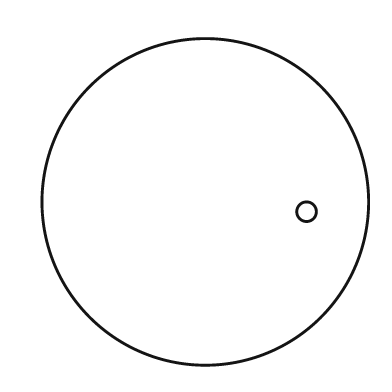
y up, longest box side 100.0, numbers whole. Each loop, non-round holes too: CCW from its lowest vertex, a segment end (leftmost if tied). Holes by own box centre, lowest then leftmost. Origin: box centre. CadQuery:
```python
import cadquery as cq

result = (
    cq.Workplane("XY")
    .moveTo(0.0, 0.0)
    .circle(50.0)
    .moveTo(31.0, -3.0)
    .circle(3.0)
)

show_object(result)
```